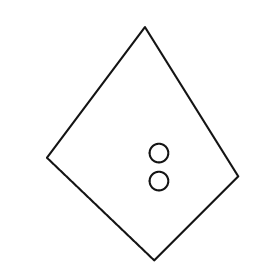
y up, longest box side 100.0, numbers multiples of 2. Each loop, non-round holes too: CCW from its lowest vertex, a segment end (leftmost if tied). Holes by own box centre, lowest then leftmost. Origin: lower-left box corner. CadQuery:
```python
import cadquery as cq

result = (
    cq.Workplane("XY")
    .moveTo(46.0, 0.0)
    .lineTo(82.0, 36.0)
    .lineTo(42.0, 100.0)
    .lineTo(0.0, 44.0)
    .close()
    .moveTo(48.0, 34.0)
    .circle(4.0)
    .moveTo(48.0, 46.0)
    .circle(4.0)
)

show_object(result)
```